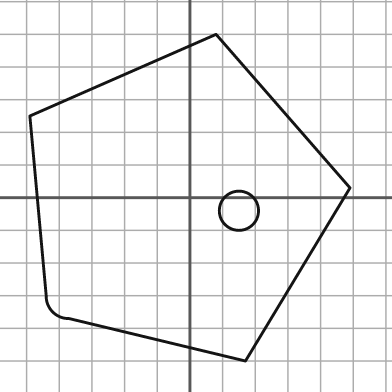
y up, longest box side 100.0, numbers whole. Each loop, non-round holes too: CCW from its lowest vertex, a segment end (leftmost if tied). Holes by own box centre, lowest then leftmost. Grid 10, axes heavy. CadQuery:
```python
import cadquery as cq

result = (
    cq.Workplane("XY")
    .moveTo(17.0, -50.0)
    .lineTo(49.0, 3.0)
    .lineTo(8.0, 50.0)
    .lineTo(-49.0, 25.0)
    .lineTo(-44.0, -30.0)
    .threePointArc((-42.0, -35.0), (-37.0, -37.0))
    .close()
    .moveTo(15.0, -4.0)
    .circle(6.0)
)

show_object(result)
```